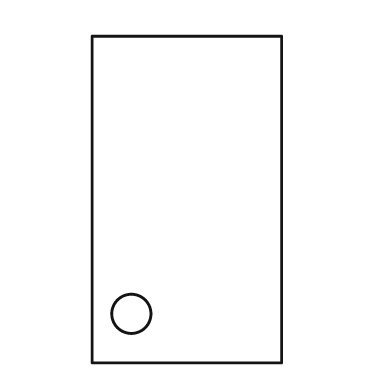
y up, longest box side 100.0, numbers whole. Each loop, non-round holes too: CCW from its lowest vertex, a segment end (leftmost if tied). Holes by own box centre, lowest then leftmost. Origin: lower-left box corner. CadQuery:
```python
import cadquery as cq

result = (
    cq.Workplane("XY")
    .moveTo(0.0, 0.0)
    .lineTo(58.0, 0.0)
    .lineTo(58.0, 100.0)
    .lineTo(0.0, 100.0)
    .close()
    .moveTo(12.0, 15.0)
    .circle(6.0)
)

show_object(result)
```